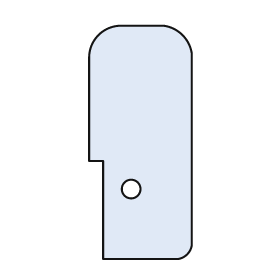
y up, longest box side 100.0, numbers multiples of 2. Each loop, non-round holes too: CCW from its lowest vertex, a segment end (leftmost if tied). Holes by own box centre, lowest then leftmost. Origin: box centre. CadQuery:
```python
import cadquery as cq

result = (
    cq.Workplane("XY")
    .moveTo(-16.0, -50.0)
    .lineTo(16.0, -50.0)
    .threePointArc((20.0, -48.0), (22.0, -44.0))
    .lineTo(22.0, 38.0)
    .threePointArc((18.0, 46.0), (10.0, 50.0))
    .lineTo(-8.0, 50.0)
    .threePointArc((-18.0, 46.0), (-22.0, 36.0))
    .lineTo(-22.0, -8.0)
    .lineTo(-16.0, -8.0)
    .close()
    .moveTo(-4.0, -20.0)
    .circle(4.0)
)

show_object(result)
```